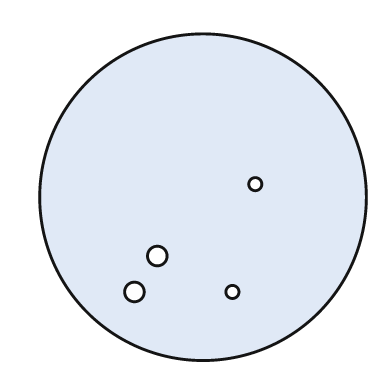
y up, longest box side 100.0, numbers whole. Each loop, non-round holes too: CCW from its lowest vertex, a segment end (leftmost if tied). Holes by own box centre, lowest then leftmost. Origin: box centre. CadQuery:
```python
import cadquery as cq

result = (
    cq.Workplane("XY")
    .moveTo(0.0, 0.0)
    .circle(50.0)
    .moveTo(-21.0, -29.0)
    .circle(3.0)
    .moveTo(9.0, -29.0)
    .circle(2.0)
    .moveTo(-14.0, -18.0)
    .circle(3.0)
    .moveTo(16.0, 4.0)
    .circle(2.0)
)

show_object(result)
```